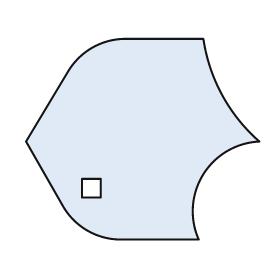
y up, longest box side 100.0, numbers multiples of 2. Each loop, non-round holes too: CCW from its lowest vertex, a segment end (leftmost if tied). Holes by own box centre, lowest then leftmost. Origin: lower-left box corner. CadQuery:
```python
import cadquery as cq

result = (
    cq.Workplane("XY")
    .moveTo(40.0, 0.0)
    .lineTo(74.0, 0.0)
    .threePointArc((76.0, 28.0), (100.0, 42.0))
    .threePointArc((84.0, 62.0), (76.0, 86.0))
    .lineTo(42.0, 86.0)
    .threePointArc((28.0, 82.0), (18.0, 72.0))
    .lineTo(0.0, 42.0)
    .lineTo(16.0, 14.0)
    .threePointArc((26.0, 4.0), (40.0, 0.0))
    .close()
    .moveTo(24.0, 18.0)
    .lineTo(32.0, 18.0)
    .lineTo(32.0, 26.0)
    .lineTo(24.0, 26.0)
    .close()
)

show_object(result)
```